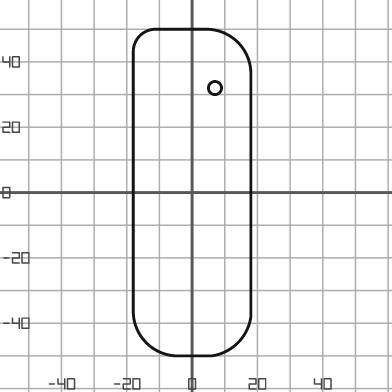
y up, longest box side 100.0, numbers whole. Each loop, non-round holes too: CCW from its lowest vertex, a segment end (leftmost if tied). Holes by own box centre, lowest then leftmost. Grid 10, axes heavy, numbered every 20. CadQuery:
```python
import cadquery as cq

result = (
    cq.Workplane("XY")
    .moveTo(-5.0, -50.0)
    .lineTo(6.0, -50.0)
    .threePointArc((14.0, -46.0), (18.0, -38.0))
    .lineTo(18.0, 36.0)
    .threePointArc((14.0, 46.0), (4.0, 50.0))
    .lineTo(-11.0, 50.0)
    .threePointArc((-16.0, 48.0), (-18.0, 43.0))
    .lineTo(-18.0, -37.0)
    .threePointArc((-14.0, -46.0), (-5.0, -50.0))
    .close()
    .moveTo(7.0, 32.0)
    .circle(2.0)
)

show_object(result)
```